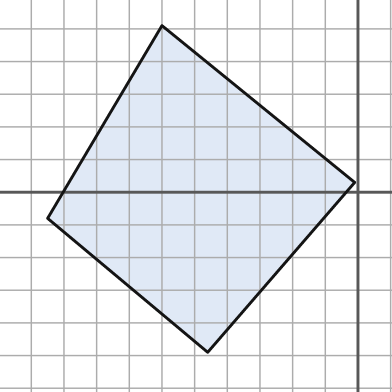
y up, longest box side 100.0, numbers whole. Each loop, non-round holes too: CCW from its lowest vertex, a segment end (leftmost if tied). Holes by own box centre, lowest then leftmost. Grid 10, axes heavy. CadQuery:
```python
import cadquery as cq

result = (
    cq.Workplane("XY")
    .moveTo(-46.0, -49.0)
    .lineTo(-1.0, 3.0)
    .lineTo(-60.0, 51.0)
    .lineTo(-95.0, -8.0)
    .close()
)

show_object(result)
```